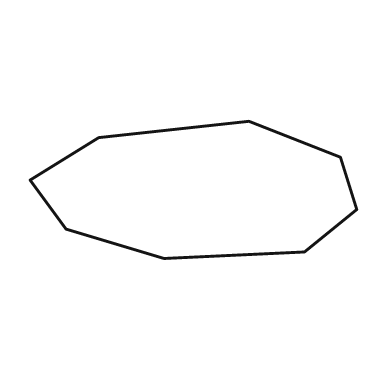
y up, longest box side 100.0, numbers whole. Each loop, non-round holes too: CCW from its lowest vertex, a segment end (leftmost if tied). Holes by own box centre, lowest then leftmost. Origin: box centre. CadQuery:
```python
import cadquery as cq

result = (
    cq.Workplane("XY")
    .moveTo(-9.0, -21.0)
    .lineTo(34.0, -19.0)
    .lineTo(50.0, -6.0)
    .lineTo(45.0, 10.0)
    .lineTo(17.0, 21.0)
    .lineTo(-29.0, 16.0)
    .lineTo(-50.0, 3.0)
    .lineTo(-39.0, -12.0)
    .close()
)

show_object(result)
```